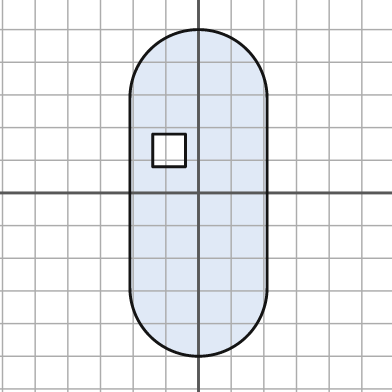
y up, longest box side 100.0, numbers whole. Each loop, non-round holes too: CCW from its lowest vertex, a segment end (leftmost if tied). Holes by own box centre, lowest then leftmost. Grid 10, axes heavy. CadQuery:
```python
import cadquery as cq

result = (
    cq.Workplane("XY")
    .moveTo(-21.0, -29.0)
    .threePointArc((0.0, -50.0), (21.0, -29.0))
    .lineTo(21.0, 29.0)
    .threePointArc((0.0, 50.0), (-21.0, 29.0))
    .close()
    .moveTo(-14.0, 8.0)
    .lineTo(-4.0, 8.0)
    .lineTo(-4.0, 18.0)
    .lineTo(-14.0, 18.0)
    .close()
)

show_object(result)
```